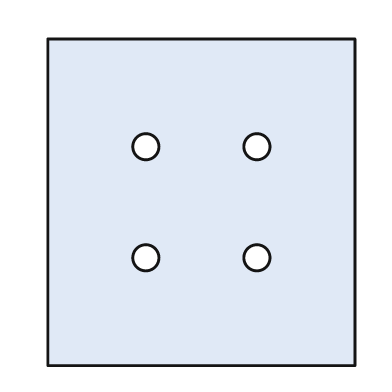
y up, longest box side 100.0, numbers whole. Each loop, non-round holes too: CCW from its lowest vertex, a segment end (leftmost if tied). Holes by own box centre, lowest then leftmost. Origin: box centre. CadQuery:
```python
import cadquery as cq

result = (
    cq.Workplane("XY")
    .moveTo(-47.0, -50.0)
    .lineTo(47.0, -50.0)
    .lineTo(47.0, 50.0)
    .lineTo(-47.0, 50.0)
    .close()
    .moveTo(-17.0, -17.0)
    .circle(4.0)
    .moveTo(17.0, -17.0)
    .circle(4.0)
    .moveTo(-17.0, 17.0)
    .circle(4.0)
    .moveTo(17.0, 17.0)
    .circle(4.0)
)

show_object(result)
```